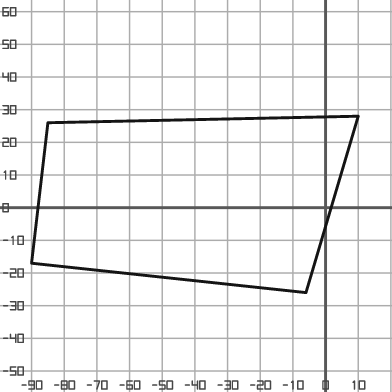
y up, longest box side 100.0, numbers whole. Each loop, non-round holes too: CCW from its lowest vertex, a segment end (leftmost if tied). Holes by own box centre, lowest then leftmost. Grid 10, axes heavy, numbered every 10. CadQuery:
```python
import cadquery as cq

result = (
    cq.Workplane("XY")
    .moveTo(-6.0, -26.0)
    .lineTo(10.0, 28.0)
    .lineTo(-85.0, 26.0)
    .lineTo(-90.0, -17.0)
    .close()
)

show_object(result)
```